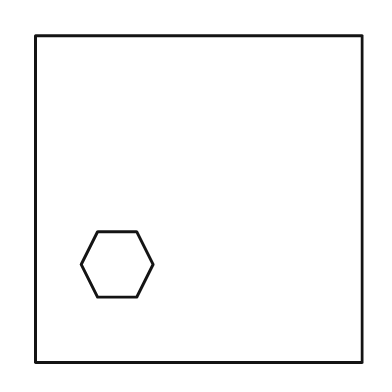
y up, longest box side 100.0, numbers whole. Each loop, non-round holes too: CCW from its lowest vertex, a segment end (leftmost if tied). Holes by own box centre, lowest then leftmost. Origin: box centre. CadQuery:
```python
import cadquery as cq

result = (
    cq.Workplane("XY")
    .moveTo(-50.0, -50.0)
    .lineTo(50.0, -50.0)
    .lineTo(50.0, 50.0)
    .lineTo(-50.0, 50.0)
    .close()
    .moveTo(-31.0, -30.0)
    .lineTo(-19.0, -30.0)
    .lineTo(-14.0, -20.0)
    .lineTo(-19.0, -10.0)
    .lineTo(-31.0, -10.0)
    .lineTo(-36.0, -20.0)
    .close()
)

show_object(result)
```